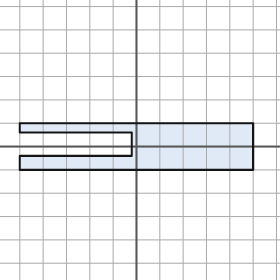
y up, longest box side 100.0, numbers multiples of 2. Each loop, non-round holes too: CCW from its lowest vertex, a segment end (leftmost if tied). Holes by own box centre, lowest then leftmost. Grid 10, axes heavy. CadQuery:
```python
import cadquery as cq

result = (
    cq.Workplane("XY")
    .moveTo(-50.0, -10.0)
    .lineTo(50.0, -10.0)
    .lineTo(50.0, 10.0)
    .lineTo(-50.0, 10.0)
    .lineTo(-50.0, 6.0)
    .lineTo(-2.0, 6.0)
    .lineTo(-2.0, -4.0)
    .lineTo(-50.0, -4.0)
    .close()
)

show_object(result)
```